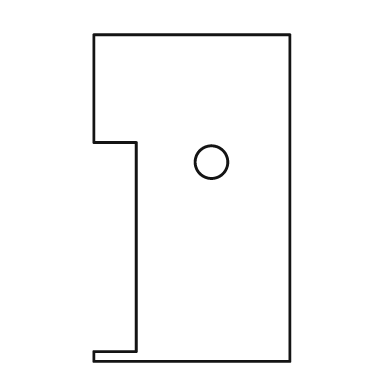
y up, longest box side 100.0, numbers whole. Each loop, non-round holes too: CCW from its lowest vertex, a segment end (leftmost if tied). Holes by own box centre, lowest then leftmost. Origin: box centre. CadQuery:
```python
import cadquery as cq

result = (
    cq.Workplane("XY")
    .moveTo(-30.0, -50.0)
    .lineTo(30.0, -50.0)
    .lineTo(30.0, 50.0)
    .lineTo(-30.0, 50.0)
    .lineTo(-30.0, 17.0)
    .lineTo(-17.0, 17.0)
    .lineTo(-17.0, -47.0)
    .lineTo(-30.0, -47.0)
    .close()
    .moveTo(6.0, 11.0)
    .circle(5.0)
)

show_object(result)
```